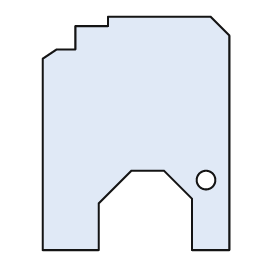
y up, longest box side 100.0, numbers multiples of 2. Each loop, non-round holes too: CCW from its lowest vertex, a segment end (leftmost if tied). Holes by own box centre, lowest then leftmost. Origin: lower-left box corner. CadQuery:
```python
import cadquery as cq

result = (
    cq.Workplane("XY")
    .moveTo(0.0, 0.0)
    .lineTo(24.0, 0.0)
    .lineTo(24.0, 20.0)
    .lineTo(38.0, 34.0)
    .lineTo(52.0, 34.0)
    .lineTo(64.0, 22.0)
    .lineTo(64.0, 0.0)
    .lineTo(80.0, 0.0)
    .lineTo(80.0, 92.0)
    .lineTo(72.0, 100.0)
    .lineTo(28.0, 100.0)
    .lineTo(28.0, 96.0)
    .lineTo(14.0, 96.0)
    .lineTo(14.0, 86.0)
    .lineTo(6.0, 86.0)
    .lineTo(0.0, 82.0)
    .close()
    .moveTo(70.0, 30.0)
    .circle(4.0)
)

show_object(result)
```